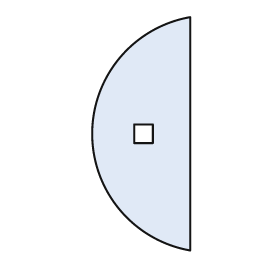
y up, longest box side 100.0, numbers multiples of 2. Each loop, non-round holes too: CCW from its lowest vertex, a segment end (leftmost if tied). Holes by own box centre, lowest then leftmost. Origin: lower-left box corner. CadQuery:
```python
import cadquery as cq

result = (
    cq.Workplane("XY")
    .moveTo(42.0, 0.0)
    .lineTo(42.0, 100.0)
    .threePointArc((0.0, 50.0), (42.0, 0.0))
    .close()
    .moveTo(18.0, 46.0)
    .lineTo(26.0, 46.0)
    .lineTo(26.0, 54.0)
    .lineTo(18.0, 54.0)
    .close()
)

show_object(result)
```